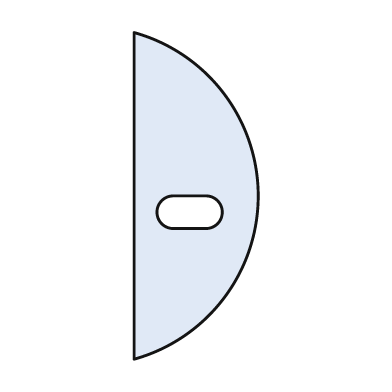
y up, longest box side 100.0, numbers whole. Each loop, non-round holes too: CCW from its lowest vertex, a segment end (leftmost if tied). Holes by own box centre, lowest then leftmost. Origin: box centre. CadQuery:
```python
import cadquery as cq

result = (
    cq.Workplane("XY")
    .moveTo(-19.0, -50.0)
    .threePointArc((19.0, 0.0), (-19.0, 50.0))
    .close()
    .moveTo(-7.0, -10.0)
    .lineTo(3.0, -10.0)
    .threePointArc((8.0, -5.0), (3.0, 0.0))
    .lineTo(-7.0, 0.0)
    .threePointArc((-12.0, -5.0), (-7.0, -10.0))
    .close()
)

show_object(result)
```